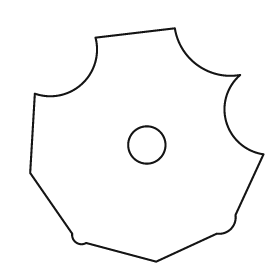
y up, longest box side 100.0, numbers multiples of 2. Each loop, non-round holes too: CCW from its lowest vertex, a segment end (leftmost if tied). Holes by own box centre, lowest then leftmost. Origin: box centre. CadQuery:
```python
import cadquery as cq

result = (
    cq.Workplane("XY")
    .moveTo(4.0, -50.0)
    .lineTo(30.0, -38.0)
    .threePointArc((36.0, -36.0), (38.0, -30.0))
    .lineTo(50.0, -4.0)
    .threePointArc((34.0, 10.0), (40.0, 30.0))
    .threePointArc((22.0, 34.0), (12.0, 50.0))
    .lineTo(-22.0, 46.0)
    .threePointArc((-28.0, 26.0), (-48.0, 22.0))
    .lineTo(-50.0, -12.0)
    .lineTo(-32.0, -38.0)
    .threePointArc((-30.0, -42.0), (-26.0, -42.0))
    .close()
    .moveTo(0.0, 0.0)
    .circle(8.0)
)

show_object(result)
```